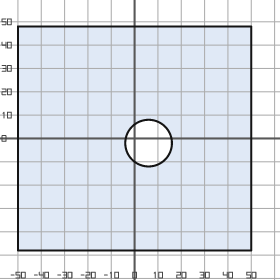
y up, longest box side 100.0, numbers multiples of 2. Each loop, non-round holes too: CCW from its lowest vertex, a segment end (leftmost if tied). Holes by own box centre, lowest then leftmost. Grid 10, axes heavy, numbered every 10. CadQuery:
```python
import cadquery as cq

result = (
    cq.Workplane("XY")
    .moveTo(-50.0, -48.0)
    .lineTo(50.0, -48.0)
    .lineTo(50.0, 48.0)
    .lineTo(-50.0, 48.0)
    .close()
    .moveTo(6.0, -2.0)
    .circle(10.0)
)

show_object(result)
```